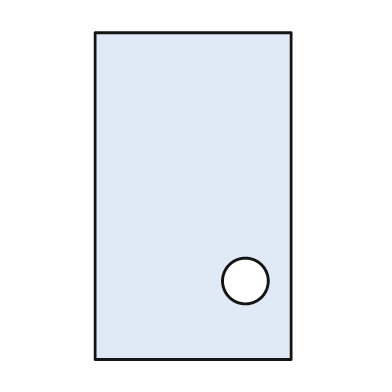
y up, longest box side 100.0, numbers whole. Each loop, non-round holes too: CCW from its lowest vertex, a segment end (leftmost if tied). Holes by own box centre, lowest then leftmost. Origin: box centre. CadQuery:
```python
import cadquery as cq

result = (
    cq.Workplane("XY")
    .moveTo(-30.0, -50.0)
    .lineTo(30.0, -50.0)
    .lineTo(30.0, 50.0)
    .lineTo(-30.0, 50.0)
    .close()
    .moveTo(16.0, -26.0)
    .circle(7.0)
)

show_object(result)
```